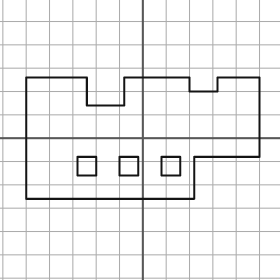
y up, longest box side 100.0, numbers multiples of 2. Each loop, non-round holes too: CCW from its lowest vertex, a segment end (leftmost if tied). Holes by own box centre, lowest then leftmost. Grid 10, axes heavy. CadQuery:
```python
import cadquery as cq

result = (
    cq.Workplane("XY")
    .moveTo(-50.0, -26.0)
    .lineTo(22.0, -26.0)
    .lineTo(22.0, -8.0)
    .lineTo(50.0, -8.0)
    .lineTo(50.0, 26.0)
    .lineTo(32.0, 26.0)
    .lineTo(32.0, 20.0)
    .lineTo(20.0, 20.0)
    .lineTo(20.0, 26.0)
    .lineTo(-8.0, 26.0)
    .lineTo(-8.0, 14.0)
    .lineTo(-24.0, 14.0)
    .lineTo(-24.0, 26.0)
    .lineTo(-50.0, 26.0)
    .close()
    .moveTo(-28.0, -16.0)
    .lineTo(-20.0, -16.0)
    .lineTo(-20.0, -8.0)
    .lineTo(-28.0, -8.0)
    .close()
    .moveTo(-10.0, -16.0)
    .lineTo(-2.0, -16.0)
    .lineTo(-2.0, -8.0)
    .lineTo(-10.0, -8.0)
    .close()
    .moveTo(8.0, -16.0)
    .lineTo(16.0, -16.0)
    .lineTo(16.0, -8.0)
    .lineTo(8.0, -8.0)
    .close()
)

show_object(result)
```